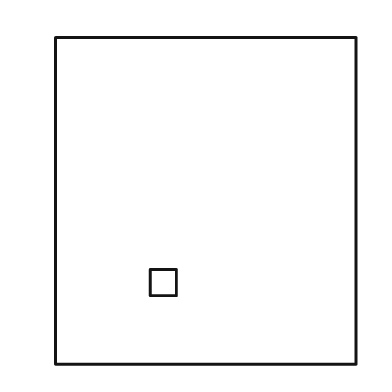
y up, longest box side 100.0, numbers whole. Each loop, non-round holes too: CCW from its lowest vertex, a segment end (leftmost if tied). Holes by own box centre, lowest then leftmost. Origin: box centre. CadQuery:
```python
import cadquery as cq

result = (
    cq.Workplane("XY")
    .moveTo(-46.0, -50.0)
    .lineTo(46.0, -50.0)
    .lineTo(46.0, 50.0)
    .lineTo(-46.0, 50.0)
    .close()
    .moveTo(-17.0, -29.0)
    .lineTo(-9.0, -29.0)
    .lineTo(-9.0, -21.0)
    .lineTo(-17.0, -21.0)
    .close()
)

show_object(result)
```